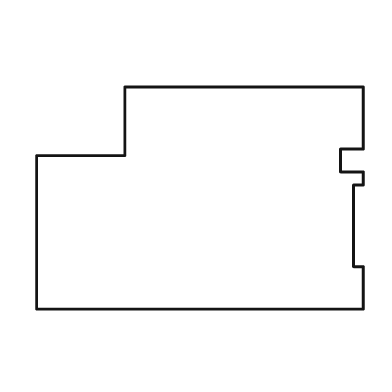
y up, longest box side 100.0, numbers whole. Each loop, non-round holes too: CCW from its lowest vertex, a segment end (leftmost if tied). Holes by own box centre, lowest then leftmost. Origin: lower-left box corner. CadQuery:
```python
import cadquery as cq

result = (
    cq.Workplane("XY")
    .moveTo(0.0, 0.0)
    .lineTo(100.0, 0.0)
    .lineTo(100.0, 13.0)
    .lineTo(97.0, 13.0)
    .lineTo(97.0, 38.0)
    .lineTo(100.0, 38.0)
    .lineTo(100.0, 42.0)
    .lineTo(93.0, 42.0)
    .lineTo(93.0, 49.0)
    .lineTo(100.0, 49.0)
    .lineTo(100.0, 68.0)
    .lineTo(27.0, 68.0)
    .lineTo(27.0, 47.0)
    .lineTo(0.0, 47.0)
    .close()
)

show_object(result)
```